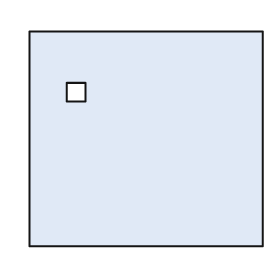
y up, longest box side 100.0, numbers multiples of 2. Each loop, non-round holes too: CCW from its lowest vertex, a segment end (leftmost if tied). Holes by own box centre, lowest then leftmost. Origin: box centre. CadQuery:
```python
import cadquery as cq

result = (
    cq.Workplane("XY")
    .moveTo(-50.0, -46.0)
    .lineTo(50.0, -46.0)
    .lineTo(50.0, 46.0)
    .lineTo(-50.0, 46.0)
    .close()
    .moveTo(-34.0, 16.0)
    .lineTo(-26.0, 16.0)
    .lineTo(-26.0, 24.0)
    .lineTo(-34.0, 24.0)
    .close()
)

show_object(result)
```